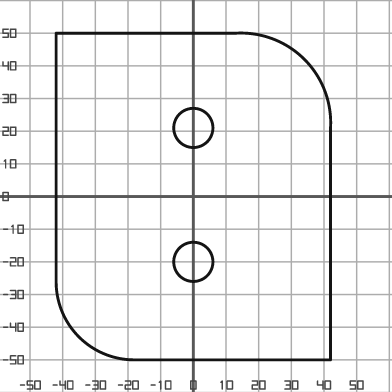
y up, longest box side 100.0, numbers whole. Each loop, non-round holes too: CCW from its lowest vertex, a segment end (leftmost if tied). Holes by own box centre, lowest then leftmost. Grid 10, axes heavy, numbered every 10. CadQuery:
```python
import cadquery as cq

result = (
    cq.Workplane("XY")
    .moveTo(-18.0, -50.0)
    .lineTo(42.0, -50.0)
    .lineTo(42.0, 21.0)
    .threePointArc((34.0, 42.0), (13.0, 50.0))
    .lineTo(-42.0, 50.0)
    .lineTo(-42.0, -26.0)
    .threePointArc((-35.0, -43.0), (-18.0, -50.0))
    .close()
    .moveTo(0.0, -20.0)
    .circle(6.0)
    .moveTo(0.0, 21.0)
    .circle(6.0)
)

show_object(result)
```